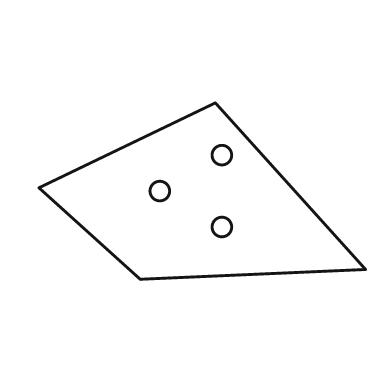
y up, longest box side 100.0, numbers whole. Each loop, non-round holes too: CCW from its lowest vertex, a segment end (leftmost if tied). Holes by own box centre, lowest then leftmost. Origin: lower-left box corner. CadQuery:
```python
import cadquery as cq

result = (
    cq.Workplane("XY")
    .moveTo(31.0, 0.0)
    .lineTo(100.0, 3.0)
    .lineTo(54.0, 54.0)
    .lineTo(0.0, 28.0)
    .close()
    .moveTo(56.0, 16.0)
    .circle(3.0)
    .moveTo(37.0, 27.0)
    .circle(3.0)
    .moveTo(56.0, 38.0)
    .circle(3.0)
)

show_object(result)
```